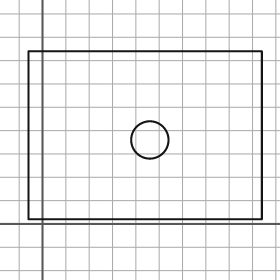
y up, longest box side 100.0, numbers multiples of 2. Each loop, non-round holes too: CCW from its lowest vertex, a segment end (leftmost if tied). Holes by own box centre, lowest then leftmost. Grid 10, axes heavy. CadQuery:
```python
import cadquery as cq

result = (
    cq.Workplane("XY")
    .moveTo(-6.0, 2.0)
    .lineTo(94.0, 2.0)
    .lineTo(94.0, 74.0)
    .lineTo(-6.0, 74.0)
    .close()
    .moveTo(46.0, 36.0)
    .circle(8.0)
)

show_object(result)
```